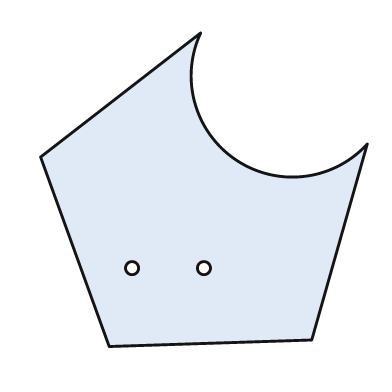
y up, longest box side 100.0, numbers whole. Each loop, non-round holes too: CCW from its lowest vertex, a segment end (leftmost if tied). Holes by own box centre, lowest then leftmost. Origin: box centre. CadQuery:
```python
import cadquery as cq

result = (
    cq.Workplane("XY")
    .moveTo(-29.0, -48.0)
    .lineTo(33.0, -46.0)
    .lineTo(50.0, 14.0)
    .threePointArc((10.0, 9.0), (-1.0, 48.0))
    .lineTo(-50.0, 10.0)
    .close()
    .moveTo(-22.0, -24.0)
    .circle(2.0)
    .moveTo(0.0, -24.0)
    .circle(2.0)
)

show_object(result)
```